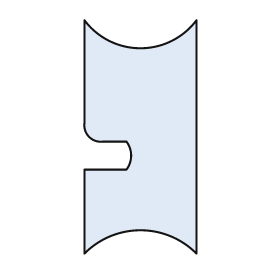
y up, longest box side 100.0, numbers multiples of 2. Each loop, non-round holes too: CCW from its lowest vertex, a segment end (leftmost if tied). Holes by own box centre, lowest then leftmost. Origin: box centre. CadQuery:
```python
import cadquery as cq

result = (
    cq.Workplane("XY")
    .moveTo(-24.0, -50.0)
    .threePointArc((0.0, -40.0), (24.0, -50.0))
    .lineTo(24.0, 50.0)
    .threePointArc((0.0, 38.0), (-24.0, 50.0))
    .lineTo(-24.0, 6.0)
    .threePointArc((-22.0, 0.0), (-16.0, -2.0))
    .lineTo(-6.0, -2.0)
    .threePointArc((-4.0, -8.0), (-6.0, -14.0))
    .lineTo(-24.0, -14.0)
    .close()
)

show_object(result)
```